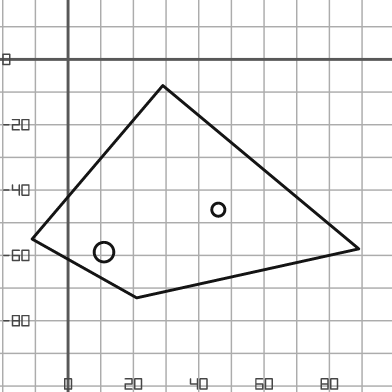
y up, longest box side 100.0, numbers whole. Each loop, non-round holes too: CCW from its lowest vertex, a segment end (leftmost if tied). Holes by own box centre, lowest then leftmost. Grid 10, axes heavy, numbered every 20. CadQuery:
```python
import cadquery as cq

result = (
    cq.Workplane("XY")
    .moveTo(21.0, -73.0)
    .lineTo(89.0, -58.0)
    .lineTo(29.0, -8.0)
    .lineTo(-11.0, -55.0)
    .close()
    .moveTo(11.0, -59.0)
    .circle(3.0)
    .moveTo(46.0, -46.0)
    .circle(2.0)
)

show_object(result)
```